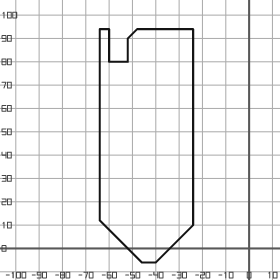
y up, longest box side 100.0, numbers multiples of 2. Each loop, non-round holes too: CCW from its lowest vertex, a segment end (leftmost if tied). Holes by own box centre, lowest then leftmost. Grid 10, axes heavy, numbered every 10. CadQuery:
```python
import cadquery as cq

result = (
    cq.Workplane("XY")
    .moveTo(-46.0, -6.0)
    .lineTo(-40.0, -6.0)
    .lineTo(-24.0, 10.0)
    .lineTo(-24.0, 94.0)
    .lineTo(-48.0, 94.0)
    .lineTo(-52.0, 90.0)
    .lineTo(-52.0, 80.0)
    .lineTo(-60.0, 80.0)
    .lineTo(-60.0, 94.0)
    .lineTo(-64.0, 94.0)
    .lineTo(-64.0, 12.0)
    .close()
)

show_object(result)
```